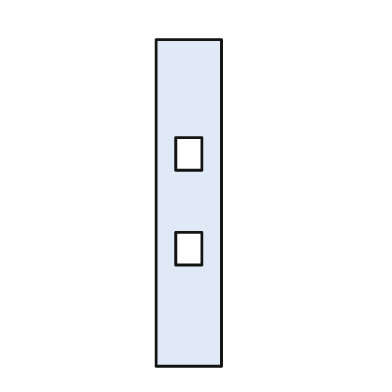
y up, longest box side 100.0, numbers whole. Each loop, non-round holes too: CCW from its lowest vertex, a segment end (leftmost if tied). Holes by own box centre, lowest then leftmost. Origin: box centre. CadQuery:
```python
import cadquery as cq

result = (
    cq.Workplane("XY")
    .moveTo(-10.0, -50.0)
    .lineTo(10.0, -50.0)
    .lineTo(10.0, 50.0)
    .lineTo(-10.0, 50.0)
    .close()
    .moveTo(-4.0, -19.0)
    .lineTo(4.0, -19.0)
    .lineTo(4.0, -9.0)
    .lineTo(-4.0, -9.0)
    .close()
    .moveTo(-4.0, 10.0)
    .lineTo(4.0, 10.0)
    .lineTo(4.0, 20.0)
    .lineTo(-4.0, 20.0)
    .close()
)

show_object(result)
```